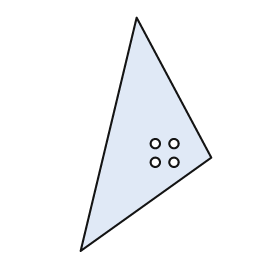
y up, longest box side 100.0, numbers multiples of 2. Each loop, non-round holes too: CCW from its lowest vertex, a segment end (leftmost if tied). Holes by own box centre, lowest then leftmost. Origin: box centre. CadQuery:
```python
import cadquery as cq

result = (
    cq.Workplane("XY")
    .moveTo(-28.0, -50.0)
    .lineTo(28.0, -10.0)
    .lineTo(-4.0, 50.0)
    .close()
    .moveTo(4.0, -12.0)
    .circle(2.0)
    .moveTo(12.0, -12.0)
    .circle(2.0)
    .moveTo(4.0, -4.0)
    .circle(2.0)
    .moveTo(12.0, -4.0)
    .circle(2.0)
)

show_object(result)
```